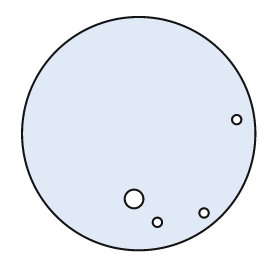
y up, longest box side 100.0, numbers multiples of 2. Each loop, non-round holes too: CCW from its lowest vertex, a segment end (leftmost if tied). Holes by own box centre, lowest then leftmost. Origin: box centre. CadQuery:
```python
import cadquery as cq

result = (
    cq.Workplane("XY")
    .moveTo(0.0, 0.0)
    .circle(50.0)
    .moveTo(8.0, -38.0)
    .circle(2.0)
    .moveTo(28.0, -34.0)
    .circle(2.0)
    .moveTo(-2.0, -28.0)
    .circle(4.0)
    .moveTo(42.0, 6.0)
    .circle(2.0)
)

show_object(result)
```